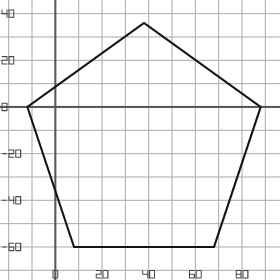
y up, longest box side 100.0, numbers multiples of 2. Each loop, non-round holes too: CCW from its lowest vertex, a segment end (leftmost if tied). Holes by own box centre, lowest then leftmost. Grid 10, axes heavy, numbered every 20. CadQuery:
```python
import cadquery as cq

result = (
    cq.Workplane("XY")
    .moveTo(8.0, -60.0)
    .lineTo(68.0, -60.0)
    .lineTo(88.0, 0.0)
    .lineTo(38.0, 36.0)
    .lineTo(-12.0, 0.0)
    .close()
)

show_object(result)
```